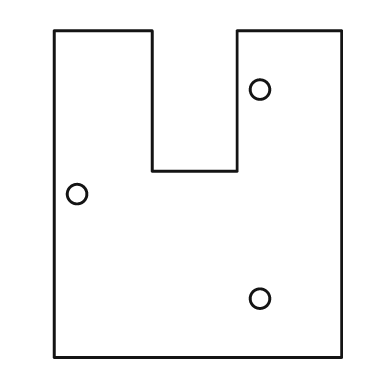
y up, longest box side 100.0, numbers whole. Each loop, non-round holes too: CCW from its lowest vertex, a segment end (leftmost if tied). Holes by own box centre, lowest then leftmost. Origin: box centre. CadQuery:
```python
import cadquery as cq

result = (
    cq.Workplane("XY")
    .moveTo(-44.0, -50.0)
    .lineTo(44.0, -50.0)
    .lineTo(44.0, 50.0)
    .lineTo(12.0, 50.0)
    .lineTo(12.0, 7.0)
    .lineTo(-14.0, 7.0)
    .lineTo(-14.0, 50.0)
    .lineTo(-44.0, 50.0)
    .close()
    .moveTo(19.0, -32.0)
    .circle(3.0)
    .moveTo(-37.0, 0.0)
    .circle(3.0)
    .moveTo(19.0, 32.0)
    .circle(3.0)
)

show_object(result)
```